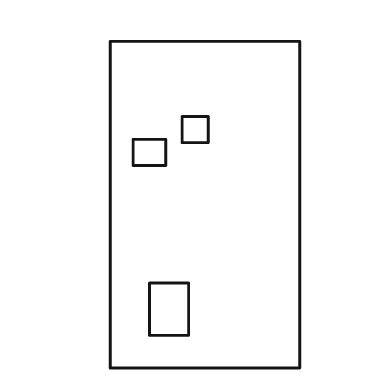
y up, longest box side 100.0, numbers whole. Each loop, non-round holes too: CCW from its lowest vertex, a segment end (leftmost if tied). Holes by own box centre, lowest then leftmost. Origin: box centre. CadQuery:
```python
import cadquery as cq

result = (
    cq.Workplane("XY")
    .moveTo(-29.0, -50.0)
    .lineTo(29.0, -50.0)
    .lineTo(29.0, 50.0)
    .lineTo(-29.0, 50.0)
    .close()
    .moveTo(-17.0, -40.0)
    .lineTo(-5.0, -40.0)
    .lineTo(-5.0, -24.0)
    .lineTo(-17.0, -24.0)
    .close()
    .moveTo(-22.0, 12.0)
    .lineTo(-12.0, 12.0)
    .lineTo(-12.0, 20.0)
    .lineTo(-22.0, 20.0)
    .close()
    .moveTo(-7.0, 19.0)
    .lineTo(1.0, 19.0)
    .lineTo(1.0, 27.0)
    .lineTo(-7.0, 27.0)
    .close()
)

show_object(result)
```